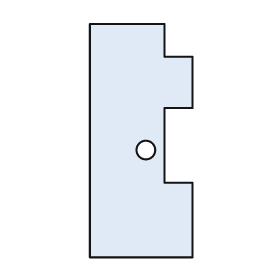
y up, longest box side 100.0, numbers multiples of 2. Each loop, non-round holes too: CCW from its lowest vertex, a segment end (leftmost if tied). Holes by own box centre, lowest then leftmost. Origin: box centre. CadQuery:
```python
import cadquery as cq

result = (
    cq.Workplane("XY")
    .moveTo(-22.0, -50.0)
    .lineTo(22.0, -50.0)
    .lineTo(22.0, -18.0)
    .lineTo(10.0, -18.0)
    .lineTo(10.0, 14.0)
    .lineTo(22.0, 14.0)
    .lineTo(22.0, 36.0)
    .lineTo(10.0, 36.0)
    .lineTo(10.0, 50.0)
    .lineTo(-22.0, 50.0)
    .close()
    .moveTo(2.0, -4.0)
    .circle(4.0)
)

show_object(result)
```